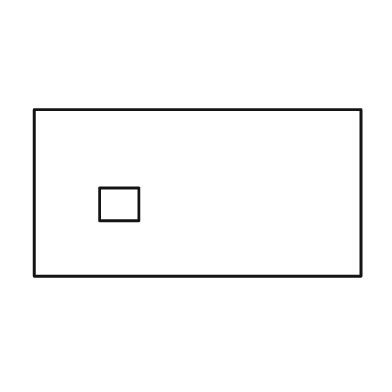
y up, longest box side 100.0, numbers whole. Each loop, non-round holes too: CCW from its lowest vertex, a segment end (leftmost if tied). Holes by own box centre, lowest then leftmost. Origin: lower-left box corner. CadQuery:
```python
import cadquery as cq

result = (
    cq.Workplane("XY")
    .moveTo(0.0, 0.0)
    .lineTo(100.0, 0.0)
    .lineTo(100.0, 51.0)
    .lineTo(0.0, 51.0)
    .close()
    .moveTo(20.0, 17.0)
    .lineTo(32.0, 17.0)
    .lineTo(32.0, 27.0)
    .lineTo(20.0, 27.0)
    .close()
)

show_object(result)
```